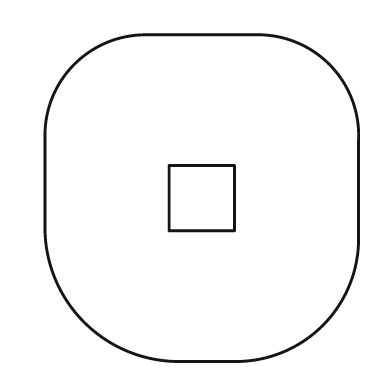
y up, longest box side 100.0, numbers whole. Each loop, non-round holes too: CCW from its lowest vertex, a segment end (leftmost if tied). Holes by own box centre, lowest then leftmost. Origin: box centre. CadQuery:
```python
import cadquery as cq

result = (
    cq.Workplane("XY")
    .moveTo(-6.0, -50.0)
    .lineTo(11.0, -50.0)
    .threePointArc((37.0, -39.0), (48.0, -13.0))
    .lineTo(48.0, 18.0)
    .threePointArc((39.0, 41.0), (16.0, 50.0))
    .lineTo(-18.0, 50.0)
    .threePointArc((-39.0, 41.0), (-48.0, 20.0))
    .lineTo(-48.0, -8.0)
    .threePointArc((-36.0, -38.0), (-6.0, -50.0))
    .close()
    .moveTo(-10.0, -10.0)
    .lineTo(10.0, -10.0)
    .lineTo(10.0, 10.0)
    .lineTo(-10.0, 10.0)
    .close()
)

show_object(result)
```